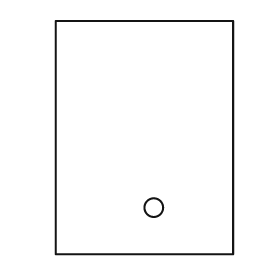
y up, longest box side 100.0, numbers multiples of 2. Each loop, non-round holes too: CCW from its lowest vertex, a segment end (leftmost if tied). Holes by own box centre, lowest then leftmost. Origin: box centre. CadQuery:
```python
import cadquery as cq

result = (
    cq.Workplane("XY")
    .moveTo(-38.0, -50.0)
    .lineTo(38.0, -50.0)
    .lineTo(38.0, 50.0)
    .lineTo(-38.0, 50.0)
    .close()
    .moveTo(4.0, -30.0)
    .circle(4.0)
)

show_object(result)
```